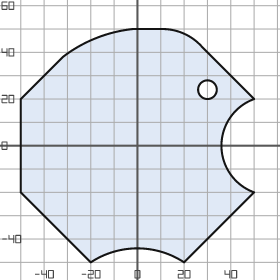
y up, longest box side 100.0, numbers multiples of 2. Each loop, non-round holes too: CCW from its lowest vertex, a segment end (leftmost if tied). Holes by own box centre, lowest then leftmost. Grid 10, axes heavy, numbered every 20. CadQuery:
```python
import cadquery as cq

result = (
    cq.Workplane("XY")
    .moveTo(-20.0, -50.0)
    .threePointArc((0.0, -44.0), (20.0, -50.0))
    .lineTo(50.0, -20.0)
    .threePointArc((36.0, 0.0), (50.0, 20.0))
    .lineTo(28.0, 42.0)
    .threePointArc((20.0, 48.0), (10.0, 50.0))
    .lineTo(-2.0, 50.0)
    .threePointArc((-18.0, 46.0), (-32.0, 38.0))
    .lineTo(-50.0, 20.0)
    .lineTo(-50.0, -20.0)
    .close()
    .moveTo(30.0, 24.0)
    .circle(4.0)
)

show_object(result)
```